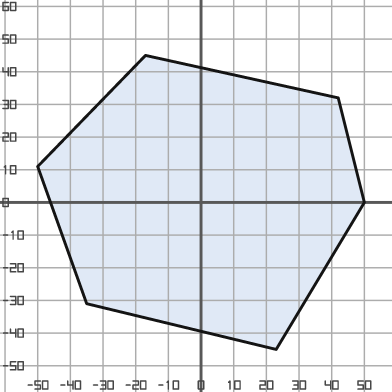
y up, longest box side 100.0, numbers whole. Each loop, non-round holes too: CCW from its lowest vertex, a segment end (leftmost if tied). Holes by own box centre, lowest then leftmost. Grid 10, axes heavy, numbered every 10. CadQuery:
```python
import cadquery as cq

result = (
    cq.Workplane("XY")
    .moveTo(23.0, -45.0)
    .lineTo(50.0, 0.0)
    .lineTo(42.0, 32.0)
    .lineTo(-17.0, 45.0)
    .lineTo(-50.0, 11.0)
    .lineTo(-35.0, -31.0)
    .close()
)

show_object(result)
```